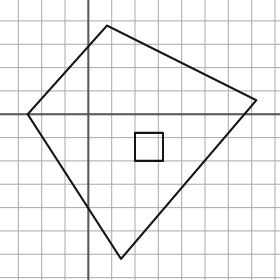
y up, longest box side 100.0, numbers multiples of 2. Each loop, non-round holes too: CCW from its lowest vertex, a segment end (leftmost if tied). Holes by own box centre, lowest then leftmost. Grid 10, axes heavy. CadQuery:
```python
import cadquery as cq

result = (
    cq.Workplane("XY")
    .moveTo(14.0, -62.0)
    .lineTo(72.0, 6.0)
    .lineTo(8.0, 38.0)
    .lineTo(-26.0, 0.0)
    .close()
    .moveTo(20.0, -20.0)
    .lineTo(32.0, -20.0)
    .lineTo(32.0, -8.0)
    .lineTo(20.0, -8.0)
    .close()
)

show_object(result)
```